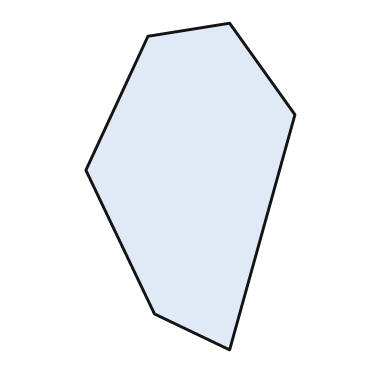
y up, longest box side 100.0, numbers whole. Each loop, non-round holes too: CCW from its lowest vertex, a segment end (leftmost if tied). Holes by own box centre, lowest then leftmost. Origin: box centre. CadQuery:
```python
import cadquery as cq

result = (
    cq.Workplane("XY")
    .moveTo(12.0, -50.0)
    .lineTo(32.0, 22.0)
    .lineTo(12.0, 50.0)
    .lineTo(-13.0, 46.0)
    .lineTo(-32.0, 5.0)
    .lineTo(-11.0, -39.0)
    .close()
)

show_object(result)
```